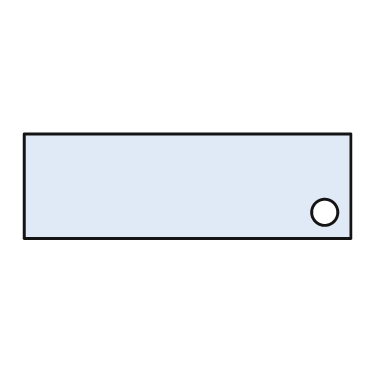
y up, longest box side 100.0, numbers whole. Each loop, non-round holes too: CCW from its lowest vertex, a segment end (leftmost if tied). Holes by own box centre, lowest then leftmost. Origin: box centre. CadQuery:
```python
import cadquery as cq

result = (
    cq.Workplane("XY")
    .moveTo(-50.0, -16.0)
    .lineTo(50.0, -16.0)
    .lineTo(50.0, 16.0)
    .lineTo(-50.0, 16.0)
    .close()
    .moveTo(42.0, -8.0)
    .circle(4.0)
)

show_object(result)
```